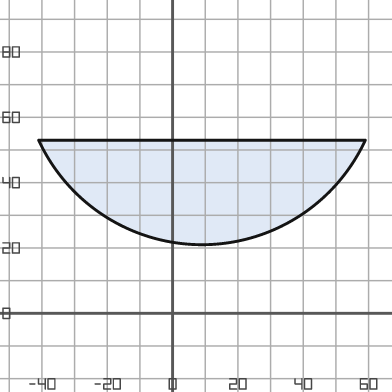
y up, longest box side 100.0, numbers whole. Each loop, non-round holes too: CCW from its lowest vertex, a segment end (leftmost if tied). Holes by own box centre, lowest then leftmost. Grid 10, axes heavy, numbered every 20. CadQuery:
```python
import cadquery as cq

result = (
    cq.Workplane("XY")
    .moveTo(-41.0, 53.0)
    .threePointArc((9.0, 21.0), (59.0, 53.0))
    .close()
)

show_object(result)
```